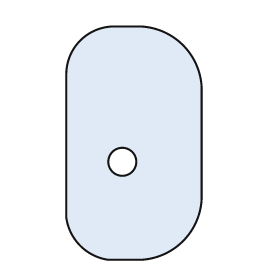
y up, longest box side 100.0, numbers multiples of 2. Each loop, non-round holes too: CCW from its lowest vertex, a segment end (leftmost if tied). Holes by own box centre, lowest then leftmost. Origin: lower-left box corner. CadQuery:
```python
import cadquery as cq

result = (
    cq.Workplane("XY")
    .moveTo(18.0, 0.0)
    .lineTo(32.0, 0.0)
    .threePointArc((50.0, 8.0), (58.0, 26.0))
    .lineTo(58.0, 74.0)
    .threePointArc((50.0, 92.0), (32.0, 100.0))
    .lineTo(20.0, 100.0)
    .threePointArc((6.0, 94.0), (0.0, 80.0))
    .lineTo(0.0, 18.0)
    .threePointArc((6.0, 6.0), (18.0, 0.0))
    .close()
    .moveTo(24.0, 42.0)
    .circle(6.0)
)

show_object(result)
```